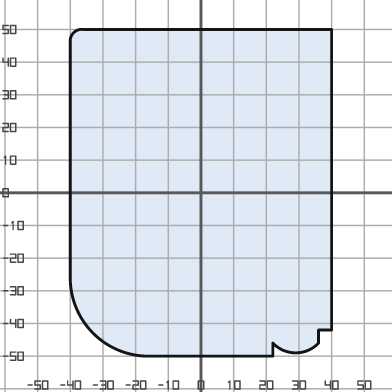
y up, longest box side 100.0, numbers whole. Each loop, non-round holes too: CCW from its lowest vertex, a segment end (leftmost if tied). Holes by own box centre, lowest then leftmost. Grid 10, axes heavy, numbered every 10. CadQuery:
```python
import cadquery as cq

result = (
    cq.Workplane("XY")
    .moveTo(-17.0, -50.0)
    .lineTo(22.0, -50.0)
    .lineTo(22.0, -46.0)
    .threePointArc((29.0, -49.0), (36.0, -46.0))
    .lineTo(36.0, -42.0)
    .lineTo(40.0, -42.0)
    .lineTo(40.0, 50.0)
    .lineTo(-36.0, 50.0)
    .threePointArc((-39.0, 49.0), (-40.0, 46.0))
    .lineTo(-40.0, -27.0)
    .threePointArc((-33.0, -43.0), (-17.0, -50.0))
    .close()
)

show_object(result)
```